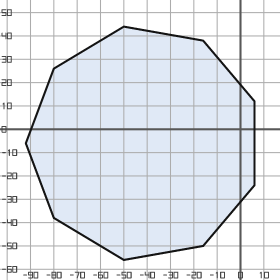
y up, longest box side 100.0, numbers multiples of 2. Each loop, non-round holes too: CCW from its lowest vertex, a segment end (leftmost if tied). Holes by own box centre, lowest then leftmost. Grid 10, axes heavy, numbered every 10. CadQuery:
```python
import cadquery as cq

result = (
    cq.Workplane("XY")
    .moveTo(-50.0, -56.0)
    .lineTo(-16.0, -50.0)
    .lineTo(6.0, -24.0)
    .lineTo(6.0, 12.0)
    .lineTo(-16.0, 38.0)
    .lineTo(-50.0, 44.0)
    .lineTo(-80.0, 26.0)
    .lineTo(-92.0, -6.0)
    .lineTo(-80.0, -38.0)
    .close()
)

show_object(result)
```